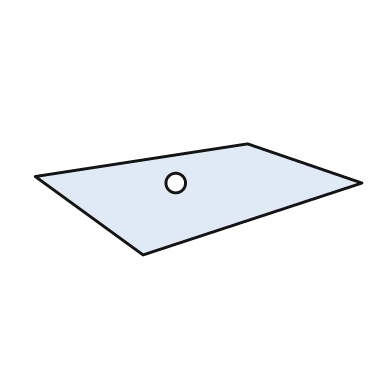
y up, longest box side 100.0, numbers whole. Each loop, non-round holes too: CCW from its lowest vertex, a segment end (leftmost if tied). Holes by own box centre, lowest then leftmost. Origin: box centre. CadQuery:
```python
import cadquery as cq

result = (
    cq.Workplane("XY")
    .moveTo(-17.0, -17.0)
    .lineTo(50.0, 5.0)
    .lineTo(15.0, 17.0)
    .lineTo(-50.0, 7.0)
    .close()
    .moveTo(-7.0, 5.0)
    .circle(3.0)
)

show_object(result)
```